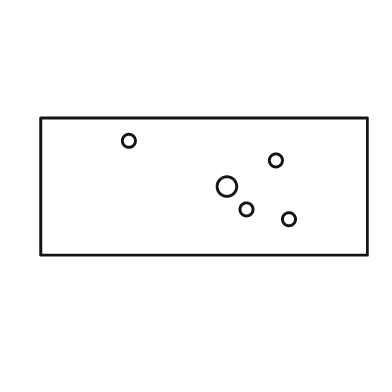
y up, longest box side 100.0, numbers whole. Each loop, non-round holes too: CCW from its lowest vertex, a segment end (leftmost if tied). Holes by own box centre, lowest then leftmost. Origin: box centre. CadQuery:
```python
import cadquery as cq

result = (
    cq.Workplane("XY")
    .moveTo(-50.0, -21.0)
    .lineTo(50.0, -21.0)
    .lineTo(50.0, 21.0)
    .lineTo(-50.0, 21.0)
    .close()
    .moveTo(26.0, -10.0)
    .circle(2.0)
    .moveTo(13.0, -7.0)
    .circle(2.0)
    .moveTo(7.0, 0.0)
    .circle(3.0)
    .moveTo(22.0, 8.0)
    .circle(2.0)
    .moveTo(-23.0, 14.0)
    .circle(2.0)
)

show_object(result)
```